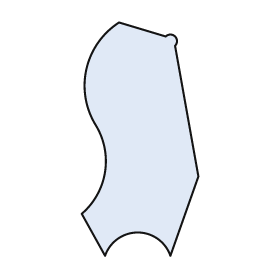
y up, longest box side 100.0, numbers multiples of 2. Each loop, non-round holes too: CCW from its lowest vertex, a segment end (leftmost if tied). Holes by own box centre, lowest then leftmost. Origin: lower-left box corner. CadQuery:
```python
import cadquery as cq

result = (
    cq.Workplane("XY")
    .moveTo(10.0, 0.0)
    .threePointArc((24.0, 10.0), (38.0, 0.0))
    .lineTo(50.0, 34.0)
    .lineTo(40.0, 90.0)
    .threePointArc((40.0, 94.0), (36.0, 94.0))
    .lineTo(16.0, 100.0)
    .threePointArc((2.0, 80.0), (6.0, 56.0))
    .threePointArc((10.0, 36.0), (0.0, 18.0))
    .close()
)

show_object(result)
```